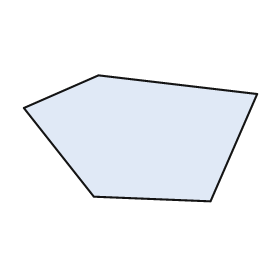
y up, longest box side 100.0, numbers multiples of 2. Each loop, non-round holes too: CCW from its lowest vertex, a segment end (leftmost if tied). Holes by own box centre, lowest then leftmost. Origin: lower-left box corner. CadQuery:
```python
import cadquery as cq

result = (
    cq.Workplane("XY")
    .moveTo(80.0, 0.0)
    .lineTo(100.0, 46.0)
    .lineTo(32.0, 54.0)
    .lineTo(0.0, 40.0)
    .lineTo(30.0, 2.0)
    .close()
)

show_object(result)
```